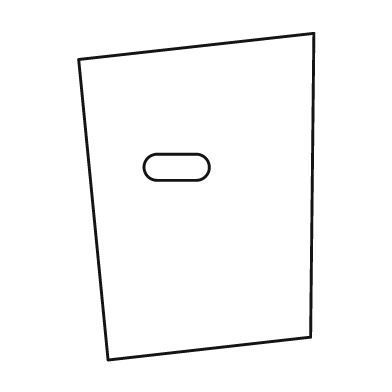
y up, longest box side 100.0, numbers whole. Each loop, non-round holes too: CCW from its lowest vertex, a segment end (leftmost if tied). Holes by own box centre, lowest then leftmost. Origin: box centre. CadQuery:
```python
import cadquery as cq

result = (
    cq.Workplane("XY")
    .moveTo(-27.0, -50.0)
    .lineTo(35.0, -43.0)
    .lineTo(36.0, 50.0)
    .lineTo(-36.0, 42.0)
    .close()
    .moveTo(-12.0, 5.0)
    .lineTo(0.0, 5.0)
    .threePointArc((4.0, 9.0), (0.0, 13.0))
    .lineTo(-12.0, 13.0)
    .threePointArc((-16.0, 9.0), (-12.0, 5.0))
    .close()
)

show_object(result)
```